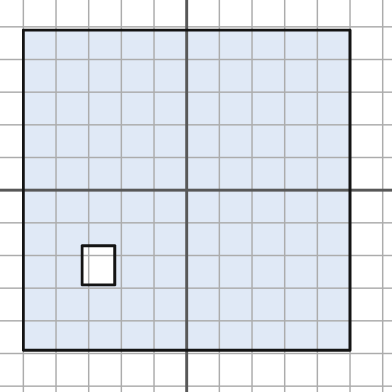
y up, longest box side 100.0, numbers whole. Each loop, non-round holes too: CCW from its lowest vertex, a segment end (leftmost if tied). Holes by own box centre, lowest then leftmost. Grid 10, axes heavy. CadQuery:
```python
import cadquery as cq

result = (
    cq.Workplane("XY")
    .moveTo(-50.0, -49.0)
    .lineTo(50.0, -49.0)
    .lineTo(50.0, 49.0)
    .lineTo(-50.0, 49.0)
    .close()
    .moveTo(-32.0, -29.0)
    .lineTo(-22.0, -29.0)
    .lineTo(-22.0, -17.0)
    .lineTo(-32.0, -17.0)
    .close()
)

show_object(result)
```